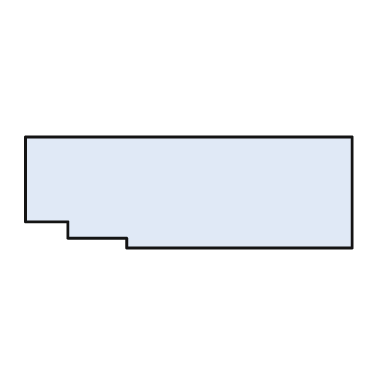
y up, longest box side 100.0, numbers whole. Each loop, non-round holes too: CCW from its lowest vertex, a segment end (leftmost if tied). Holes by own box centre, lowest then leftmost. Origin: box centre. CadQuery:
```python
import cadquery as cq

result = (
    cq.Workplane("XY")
    .moveTo(-19.0, -17.0)
    .lineTo(50.0, -17.0)
    .lineTo(50.0, 17.0)
    .lineTo(-50.0, 17.0)
    .lineTo(-50.0, -9.0)
    .lineTo(-37.0, -9.0)
    .lineTo(-37.0, -14.0)
    .lineTo(-19.0, -14.0)
    .close()
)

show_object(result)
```